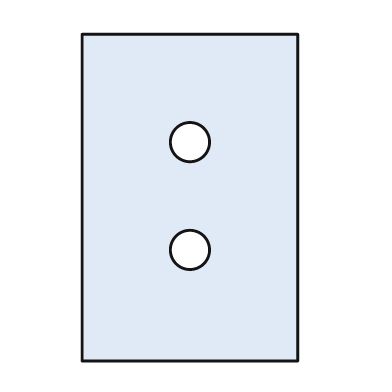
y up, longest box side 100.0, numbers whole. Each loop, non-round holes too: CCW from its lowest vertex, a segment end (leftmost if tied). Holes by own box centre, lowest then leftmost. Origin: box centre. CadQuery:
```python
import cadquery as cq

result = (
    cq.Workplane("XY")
    .moveTo(-33.0, -50.0)
    .lineTo(33.0, -50.0)
    .lineTo(33.0, 50.0)
    .lineTo(-33.0, 50.0)
    .close()
    .moveTo(0.0, -16.0)
    .circle(6.0)
    .moveTo(0.0, 17.0)
    .circle(6.0)
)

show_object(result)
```